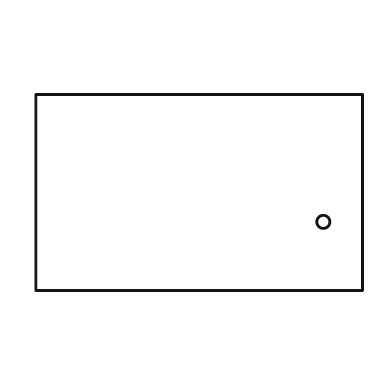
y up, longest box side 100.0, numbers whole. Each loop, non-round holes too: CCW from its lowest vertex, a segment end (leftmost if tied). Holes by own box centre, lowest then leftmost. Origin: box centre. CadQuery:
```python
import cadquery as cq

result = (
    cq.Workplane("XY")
    .moveTo(-50.0, -30.0)
    .lineTo(50.0, -30.0)
    .lineTo(50.0, 30.0)
    .lineTo(-50.0, 30.0)
    .close()
    .moveTo(38.0, -9.0)
    .circle(2.0)
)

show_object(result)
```